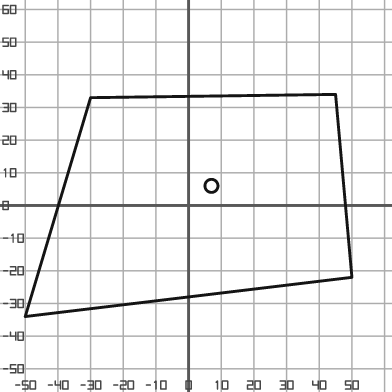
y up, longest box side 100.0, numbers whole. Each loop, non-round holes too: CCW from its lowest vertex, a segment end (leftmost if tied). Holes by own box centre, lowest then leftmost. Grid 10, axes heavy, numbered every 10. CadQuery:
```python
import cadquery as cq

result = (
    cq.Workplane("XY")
    .moveTo(-50.0, -34.0)
    .lineTo(50.0, -22.0)
    .lineTo(45.0, 34.0)
    .lineTo(-30.0, 33.0)
    .close()
    .moveTo(7.0, 6.0)
    .circle(2.0)
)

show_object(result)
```